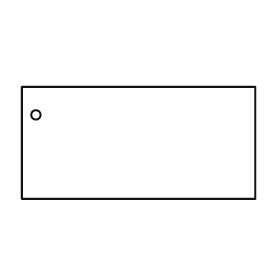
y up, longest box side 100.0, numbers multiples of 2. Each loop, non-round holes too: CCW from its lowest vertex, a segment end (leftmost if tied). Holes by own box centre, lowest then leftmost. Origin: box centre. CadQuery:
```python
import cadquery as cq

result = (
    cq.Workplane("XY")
    .moveTo(-50.0, -24.0)
    .lineTo(50.0, -24.0)
    .lineTo(50.0, 24.0)
    .lineTo(-50.0, 24.0)
    .close()
    .moveTo(-44.0, 12.0)
    .circle(2.0)
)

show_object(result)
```